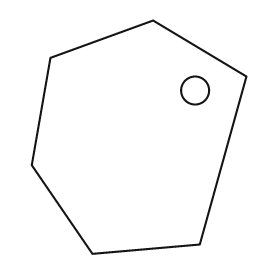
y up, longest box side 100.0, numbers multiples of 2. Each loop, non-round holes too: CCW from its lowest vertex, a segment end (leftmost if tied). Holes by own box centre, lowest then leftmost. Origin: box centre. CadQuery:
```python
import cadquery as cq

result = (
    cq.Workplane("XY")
    .moveTo(-20.0, -50.0)
    .lineTo(26.0, -46.0)
    .lineTo(46.0, 26.0)
    .lineTo(6.0, 50.0)
    .lineTo(-38.0, 34.0)
    .lineTo(-46.0, -12.0)
    .close()
    .moveTo(24.0, 20.0)
    .circle(6.0)
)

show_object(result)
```